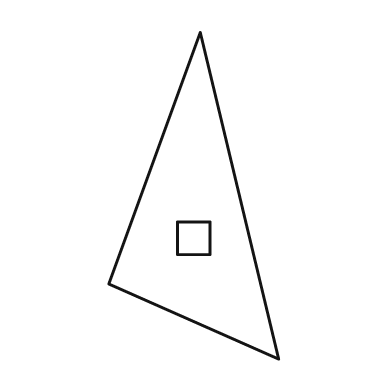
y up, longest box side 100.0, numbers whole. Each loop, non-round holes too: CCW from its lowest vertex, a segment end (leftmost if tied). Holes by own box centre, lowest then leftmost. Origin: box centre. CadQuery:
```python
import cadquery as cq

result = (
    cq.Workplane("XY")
    .moveTo(26.0, -50.0)
    .lineTo(2.0, 50.0)
    .lineTo(-26.0, -27.0)
    .close()
    .moveTo(-5.0, -18.0)
    .lineTo(5.0, -18.0)
    .lineTo(5.0, -8.0)
    .lineTo(-5.0, -8.0)
    .close()
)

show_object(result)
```